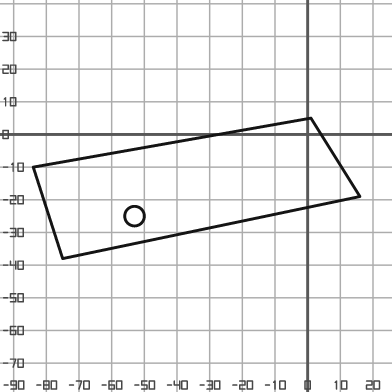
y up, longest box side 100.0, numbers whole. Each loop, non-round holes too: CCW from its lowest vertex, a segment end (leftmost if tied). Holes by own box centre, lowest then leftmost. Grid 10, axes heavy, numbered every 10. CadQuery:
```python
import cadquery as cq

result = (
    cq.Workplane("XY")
    .moveTo(-75.0, -38.0)
    .lineTo(16.0, -19.0)
    .lineTo(1.0, 5.0)
    .lineTo(-84.0, -10.0)
    .close()
    .moveTo(-53.0, -25.0)
    .circle(3.0)
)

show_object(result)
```